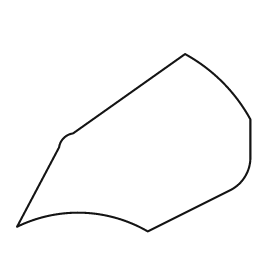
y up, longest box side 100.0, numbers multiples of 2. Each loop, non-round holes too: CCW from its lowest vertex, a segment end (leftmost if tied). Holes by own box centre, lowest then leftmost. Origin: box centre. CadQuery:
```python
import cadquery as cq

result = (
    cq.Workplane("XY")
    .moveTo(6.0, -38.0)
    .lineTo(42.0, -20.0)
    .threePointArc((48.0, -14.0), (50.0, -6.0))
    .lineTo(50.0, 10.0)
    .threePointArc((38.0, 26.0), (22.0, 38.0))
    .lineTo(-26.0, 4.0)
    .threePointArc((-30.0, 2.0), (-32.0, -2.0))
    .lineTo(-50.0, -36.0)
    .threePointArc((-22.0, -30.0), (6.0, -38.0))
    .close()
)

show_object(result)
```